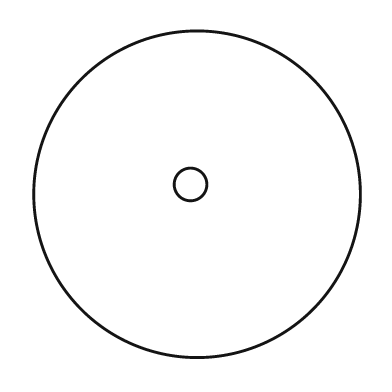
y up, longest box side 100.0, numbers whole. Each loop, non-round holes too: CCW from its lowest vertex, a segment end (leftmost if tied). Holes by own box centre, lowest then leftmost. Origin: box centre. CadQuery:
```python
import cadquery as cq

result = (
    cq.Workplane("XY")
    .moveTo(0.0, 0.0)
    .circle(50.0)
    .moveTo(-2.0, 3.0)
    .circle(5.0)
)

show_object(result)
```